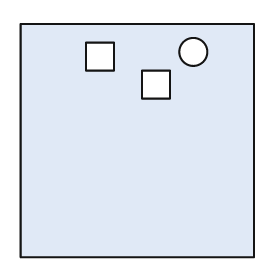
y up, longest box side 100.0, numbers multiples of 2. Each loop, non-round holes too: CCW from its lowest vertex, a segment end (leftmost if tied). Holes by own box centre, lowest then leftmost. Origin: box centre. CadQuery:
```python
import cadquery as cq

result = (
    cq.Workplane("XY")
    .moveTo(-50.0, -50.0)
    .lineTo(50.0, -50.0)
    .lineTo(50.0, 50.0)
    .lineTo(-50.0, 50.0)
    .close()
    .moveTo(2.0, 18.0)
    .lineTo(14.0, 18.0)
    .lineTo(14.0, 30.0)
    .lineTo(2.0, 30.0)
    .close()
    .moveTo(-22.0, 30.0)
    .lineTo(-10.0, 30.0)
    .lineTo(-10.0, 42.0)
    .lineTo(-22.0, 42.0)
    .close()
    .moveTo(24.0, 38.0)
    .circle(6.0)
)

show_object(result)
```